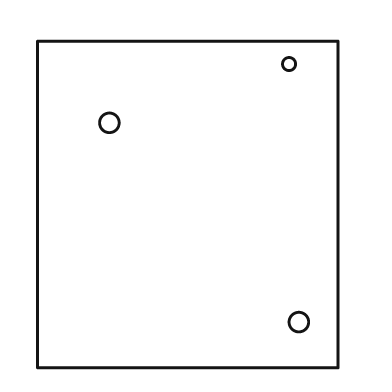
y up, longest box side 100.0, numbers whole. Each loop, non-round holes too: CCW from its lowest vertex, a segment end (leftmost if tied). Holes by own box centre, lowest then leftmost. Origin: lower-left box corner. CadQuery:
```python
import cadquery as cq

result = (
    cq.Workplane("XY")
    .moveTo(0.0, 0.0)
    .lineTo(92.0, 0.0)
    .lineTo(92.0, 100.0)
    .lineTo(0.0, 100.0)
    .close()
    .moveTo(80.0, 14.0)
    .circle(3.0)
    .moveTo(22.0, 75.0)
    .circle(3.0)
    .moveTo(77.0, 93.0)
    .circle(2.0)
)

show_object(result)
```